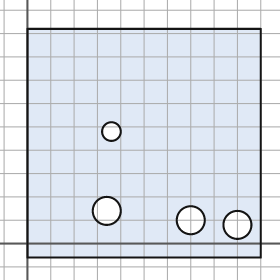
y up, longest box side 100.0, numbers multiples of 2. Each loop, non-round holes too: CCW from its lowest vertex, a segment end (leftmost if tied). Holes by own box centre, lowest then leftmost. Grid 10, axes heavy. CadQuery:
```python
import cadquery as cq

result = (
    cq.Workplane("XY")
    .moveTo(0.0, -6.0)
    .lineTo(100.0, -6.0)
    .lineTo(100.0, 92.0)
    .lineTo(0.0, 92.0)
    .close()
    .moveTo(90.0, 8.0)
    .circle(6.0)
    .moveTo(70.0, 10.0)
    .circle(6.0)
    .moveTo(34.0, 14.0)
    .circle(6.0)
    .moveTo(36.0, 48.0)
    .circle(4.0)
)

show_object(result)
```